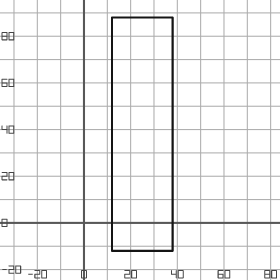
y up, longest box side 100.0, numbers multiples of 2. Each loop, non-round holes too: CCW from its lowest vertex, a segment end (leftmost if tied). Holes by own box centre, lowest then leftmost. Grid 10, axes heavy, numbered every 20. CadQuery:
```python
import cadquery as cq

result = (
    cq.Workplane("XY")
    .moveTo(12.0, -12.0)
    .lineTo(38.0, -12.0)
    .lineTo(38.0, 88.0)
    .lineTo(12.0, 88.0)
    .close()
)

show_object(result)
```